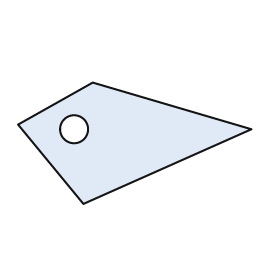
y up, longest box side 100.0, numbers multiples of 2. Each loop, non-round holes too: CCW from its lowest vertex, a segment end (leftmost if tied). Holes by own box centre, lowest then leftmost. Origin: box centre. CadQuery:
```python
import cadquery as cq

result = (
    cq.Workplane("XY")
    .moveTo(-22.0, -26.0)
    .lineTo(50.0, 6.0)
    .lineTo(-18.0, 26.0)
    .lineTo(-50.0, 8.0)
    .close()
    .moveTo(-26.0, 6.0)
    .circle(6.0)
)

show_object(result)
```